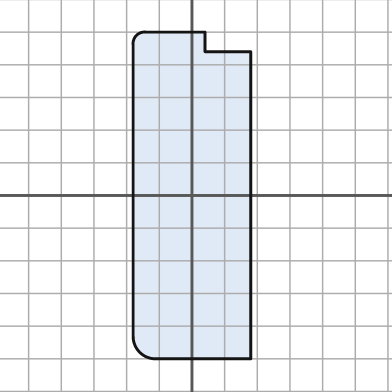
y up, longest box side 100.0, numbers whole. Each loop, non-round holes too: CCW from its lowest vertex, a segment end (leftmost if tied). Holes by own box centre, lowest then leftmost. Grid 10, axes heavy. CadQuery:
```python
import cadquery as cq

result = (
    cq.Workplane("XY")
    .moveTo(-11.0, -50.0)
    .lineTo(18.0, -50.0)
    .lineTo(18.0, 44.0)
    .lineTo(4.0, 44.0)
    .lineTo(4.0, 50.0)
    .lineTo(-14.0, 50.0)
    .threePointArc((-17.0, 49.0), (-18.0, 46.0))
    .lineTo(-18.0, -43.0)
    .threePointArc((-16.0, -48.0), (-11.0, -50.0))
    .close()
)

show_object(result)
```